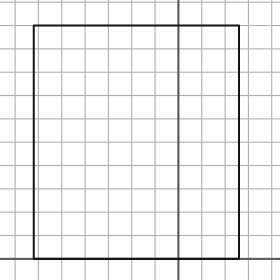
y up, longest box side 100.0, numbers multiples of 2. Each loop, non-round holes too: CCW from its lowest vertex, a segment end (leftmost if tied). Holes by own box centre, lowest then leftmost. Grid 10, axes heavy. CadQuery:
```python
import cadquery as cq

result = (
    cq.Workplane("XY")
    .moveTo(-62.0, 0.0)
    .lineTo(26.0, 0.0)
    .lineTo(26.0, 100.0)
    .lineTo(-62.0, 100.0)
    .close()
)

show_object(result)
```